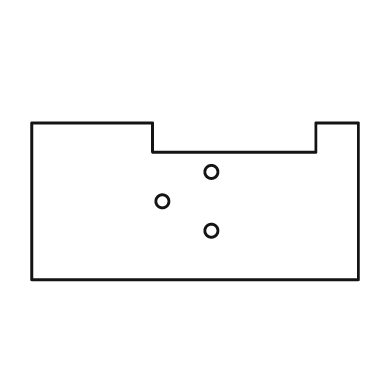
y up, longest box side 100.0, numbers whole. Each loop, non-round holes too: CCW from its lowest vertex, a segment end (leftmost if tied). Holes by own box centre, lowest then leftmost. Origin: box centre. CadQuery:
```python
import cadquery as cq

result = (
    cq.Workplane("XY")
    .moveTo(-50.0, -24.0)
    .lineTo(50.0, -24.0)
    .lineTo(50.0, 24.0)
    .lineTo(37.0, 24.0)
    .lineTo(37.0, 15.0)
    .lineTo(-13.0, 15.0)
    .lineTo(-13.0, 24.0)
    .lineTo(-50.0, 24.0)
    .close()
    .moveTo(5.0, -9.0)
    .circle(2.0)
    .moveTo(-10.0, 0.0)
    .circle(2.0)
    .moveTo(5.0, 9.0)
    .circle(2.0)
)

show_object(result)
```